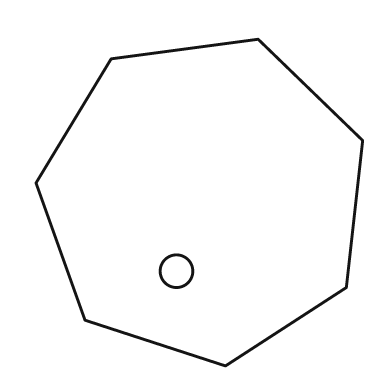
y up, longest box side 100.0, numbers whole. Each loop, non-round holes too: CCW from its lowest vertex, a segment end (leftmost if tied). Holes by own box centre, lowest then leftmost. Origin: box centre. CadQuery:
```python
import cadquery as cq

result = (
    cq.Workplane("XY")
    .moveTo(8.0, -50.0)
    .lineTo(45.0, -26.0)
    .lineTo(50.0, 19.0)
    .lineTo(18.0, 50.0)
    .lineTo(-27.0, 44.0)
    .lineTo(-50.0, 6.0)
    .lineTo(-35.0, -36.0)
    .close()
    .moveTo(-7.0, -21.0)
    .circle(5.0)
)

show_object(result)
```